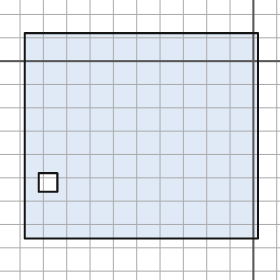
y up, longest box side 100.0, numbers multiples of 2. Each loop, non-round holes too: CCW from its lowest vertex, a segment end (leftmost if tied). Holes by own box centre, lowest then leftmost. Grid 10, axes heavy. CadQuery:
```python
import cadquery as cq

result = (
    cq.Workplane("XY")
    .moveTo(-98.0, -76.0)
    .lineTo(2.0, -76.0)
    .lineTo(2.0, 12.0)
    .lineTo(-98.0, 12.0)
    .close()
    .moveTo(-92.0, -56.0)
    .lineTo(-84.0, -56.0)
    .lineTo(-84.0, -48.0)
    .lineTo(-92.0, -48.0)
    .close()
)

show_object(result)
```